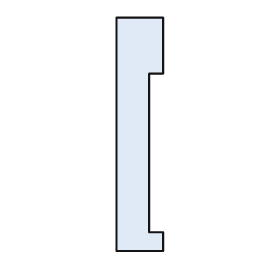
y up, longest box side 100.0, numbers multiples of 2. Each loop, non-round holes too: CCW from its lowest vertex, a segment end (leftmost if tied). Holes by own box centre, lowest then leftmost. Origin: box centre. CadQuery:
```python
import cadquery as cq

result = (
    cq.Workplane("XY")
    .moveTo(-10.0, -50.0)
    .lineTo(10.0, -50.0)
    .lineTo(10.0, -42.0)
    .lineTo(4.0, -42.0)
    .lineTo(4.0, 26.0)
    .lineTo(10.0, 26.0)
    .lineTo(10.0, 50.0)
    .lineTo(-10.0, 50.0)
    .close()
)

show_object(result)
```